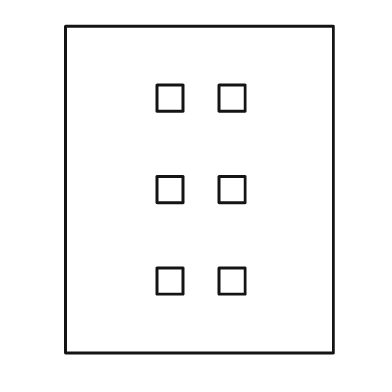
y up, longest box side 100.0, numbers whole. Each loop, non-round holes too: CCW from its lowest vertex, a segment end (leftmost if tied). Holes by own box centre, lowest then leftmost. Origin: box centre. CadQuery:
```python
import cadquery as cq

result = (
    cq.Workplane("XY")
    .moveTo(-41.0, -50.0)
    .lineTo(41.0, -50.0)
    .lineTo(41.0, 50.0)
    .lineTo(-41.0, 50.0)
    .close()
    .moveTo(-13.0, -32.0)
    .lineTo(-5.0, -32.0)
    .lineTo(-5.0, -24.0)
    .lineTo(-13.0, -24.0)
    .close()
    .moveTo(6.0, -32.0)
    .lineTo(14.0, -32.0)
    .lineTo(14.0, -24.0)
    .lineTo(6.0, -24.0)
    .close()
    .moveTo(-13.0, -4.0)
    .lineTo(-5.0, -4.0)
    .lineTo(-5.0, 4.0)
    .lineTo(-13.0, 4.0)
    .close()
    .moveTo(6.0, -4.0)
    .lineTo(14.0, -4.0)
    .lineTo(14.0, 4.0)
    .lineTo(6.0, 4.0)
    .close()
    .moveTo(-13.0, 24.0)
    .lineTo(-5.0, 24.0)
    .lineTo(-5.0, 32.0)
    .lineTo(-13.0, 32.0)
    .close()
    .moveTo(6.0, 24.0)
    .lineTo(14.0, 24.0)
    .lineTo(14.0, 32.0)
    .lineTo(6.0, 32.0)
    .close()
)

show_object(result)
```